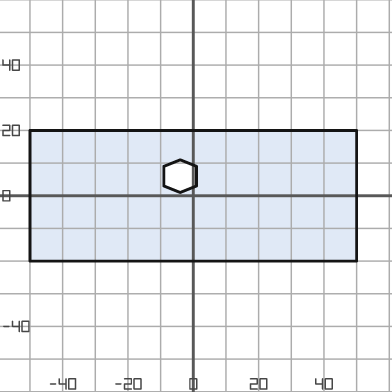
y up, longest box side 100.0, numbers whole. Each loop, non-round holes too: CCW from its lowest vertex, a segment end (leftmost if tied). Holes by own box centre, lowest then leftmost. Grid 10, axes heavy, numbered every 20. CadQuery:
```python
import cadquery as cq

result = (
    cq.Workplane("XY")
    .moveTo(-50.0, -20.0)
    .lineTo(50.0, -20.0)
    .lineTo(50.0, 20.0)
    .lineTo(-50.0, 20.0)
    .close()
    .moveTo(-4.0, 1.0)
    .lineTo(1.0, 3.0)
    .lineTo(1.0, 9.0)
    .lineTo(-4.0, 11.0)
    .lineTo(-9.0, 9.0)
    .lineTo(-9.0, 3.0)
    .close()
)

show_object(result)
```